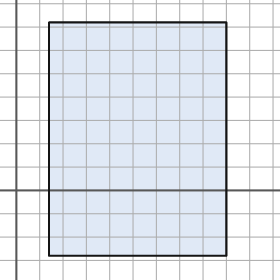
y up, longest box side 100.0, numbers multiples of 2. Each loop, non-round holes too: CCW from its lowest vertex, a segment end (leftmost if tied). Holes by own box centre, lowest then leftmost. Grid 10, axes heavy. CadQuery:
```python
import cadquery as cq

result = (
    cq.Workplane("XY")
    .moveTo(14.0, -28.0)
    .lineTo(90.0, -28.0)
    .lineTo(90.0, 72.0)
    .lineTo(14.0, 72.0)
    .close()
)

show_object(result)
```